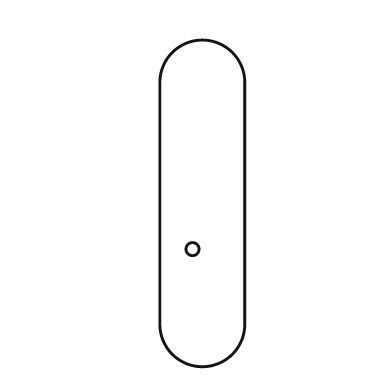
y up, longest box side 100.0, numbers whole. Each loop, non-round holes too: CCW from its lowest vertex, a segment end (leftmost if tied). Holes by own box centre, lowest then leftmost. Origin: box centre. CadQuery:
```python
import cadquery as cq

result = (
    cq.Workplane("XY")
    .moveTo(-13.0, -37.0)
    .threePointArc((0.0, -50.0), (13.0, -37.0))
    .lineTo(13.0, 37.0)
    .threePointArc((0.0, 50.0), (-13.0, 37.0))
    .close()
    .moveTo(-3.0, -14.0)
    .circle(2.0)
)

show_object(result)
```